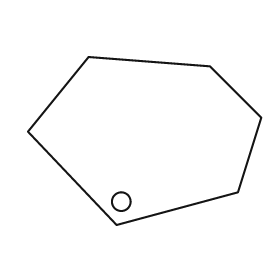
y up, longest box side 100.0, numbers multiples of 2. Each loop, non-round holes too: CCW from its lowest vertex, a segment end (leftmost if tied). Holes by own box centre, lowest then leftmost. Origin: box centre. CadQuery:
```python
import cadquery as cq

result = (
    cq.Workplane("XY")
    .moveTo(-12.0, -36.0)
    .lineTo(40.0, -22.0)
    .lineTo(50.0, 10.0)
    .lineTo(28.0, 32.0)
    .lineTo(-24.0, 36.0)
    .lineTo(-50.0, 4.0)
    .close()
    .moveTo(-10.0, -26.0)
    .circle(4.0)
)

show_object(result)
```